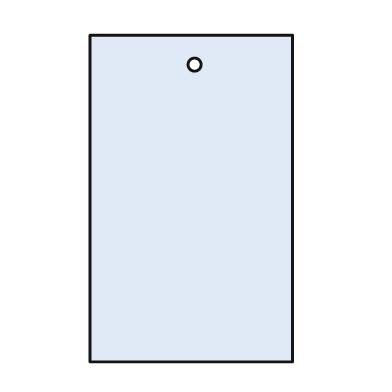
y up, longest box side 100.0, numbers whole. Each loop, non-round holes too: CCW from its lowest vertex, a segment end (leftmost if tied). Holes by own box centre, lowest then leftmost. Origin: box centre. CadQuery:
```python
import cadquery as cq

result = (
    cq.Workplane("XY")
    .moveTo(-31.0, -50.0)
    .lineTo(31.0, -50.0)
    .lineTo(31.0, 50.0)
    .lineTo(-31.0, 50.0)
    .close()
    .moveTo(1.0, 41.0)
    .circle(2.0)
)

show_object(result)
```